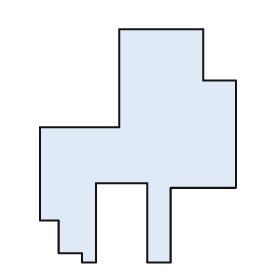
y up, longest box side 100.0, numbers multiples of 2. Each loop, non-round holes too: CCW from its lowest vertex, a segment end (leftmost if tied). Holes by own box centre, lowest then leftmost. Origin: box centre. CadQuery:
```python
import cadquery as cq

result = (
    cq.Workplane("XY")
    .moveTo(-24.0, -50.0)
    .lineTo(-18.0, -50.0)
    .lineTo(-18.0, -16.0)
    .lineTo(4.0, -16.0)
    .lineTo(4.0, -50.0)
    .lineTo(14.0, -50.0)
    .lineTo(14.0, -18.0)
    .lineTo(42.0, -18.0)
    .lineTo(42.0, 28.0)
    .lineTo(28.0, 28.0)
    .lineTo(28.0, 50.0)
    .lineTo(-8.0, 50.0)
    .lineTo(-8.0, 8.0)
    .lineTo(-42.0, 8.0)
    .lineTo(-42.0, -32.0)
    .lineTo(-34.0, -32.0)
    .lineTo(-34.0, -46.0)
    .lineTo(-24.0, -46.0)
    .close()
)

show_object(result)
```